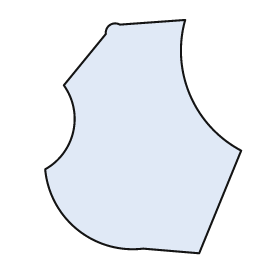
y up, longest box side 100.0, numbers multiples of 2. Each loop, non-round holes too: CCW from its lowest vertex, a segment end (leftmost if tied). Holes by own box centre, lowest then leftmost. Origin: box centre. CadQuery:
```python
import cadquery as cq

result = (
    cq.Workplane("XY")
    .moveTo(24.0, -50.0)
    .lineTo(42.0, -6.0)
    .threePointArc((20.0, 18.0), (18.0, 50.0))
    .lineTo(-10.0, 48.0)
    .threePointArc((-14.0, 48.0), (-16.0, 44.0))
    .lineTo(-34.0, 22.0)
    .threePointArc((-30.0, 2.0), (-42.0, -14.0))
    .threePointArc((-28.0, -40.0), (0.0, -48.0))
    .close()
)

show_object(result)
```